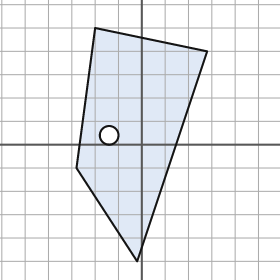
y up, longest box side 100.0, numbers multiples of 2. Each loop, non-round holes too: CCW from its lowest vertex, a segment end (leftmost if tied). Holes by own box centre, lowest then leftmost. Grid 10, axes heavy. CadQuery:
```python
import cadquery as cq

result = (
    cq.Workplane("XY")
    .moveTo(-2.0, -50.0)
    .lineTo(28.0, 40.0)
    .lineTo(-20.0, 50.0)
    .lineTo(-28.0, -10.0)
    .close()
    .moveTo(-14.0, 4.0)
    .circle(4.0)
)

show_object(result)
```